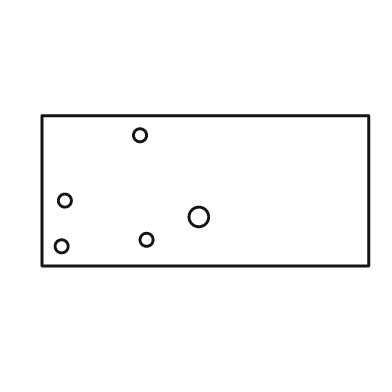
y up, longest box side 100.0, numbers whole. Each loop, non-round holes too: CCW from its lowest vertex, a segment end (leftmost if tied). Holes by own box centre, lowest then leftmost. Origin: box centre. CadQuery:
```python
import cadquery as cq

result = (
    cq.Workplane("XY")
    .moveTo(-50.0, -23.0)
    .lineTo(50.0, -23.0)
    .lineTo(50.0, 23.0)
    .lineTo(-50.0, 23.0)
    .close()
    .moveTo(-44.0, -17.0)
    .circle(2.0)
    .moveTo(-18.0, -15.0)
    .circle(2.0)
    .moveTo(-2.0, -8.0)
    .circle(3.0)
    .moveTo(-43.0, -3.0)
    .circle(2.0)
    .moveTo(-20.0, 17.0)
    .circle(2.0)
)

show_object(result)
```